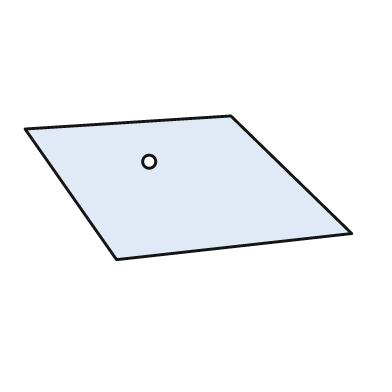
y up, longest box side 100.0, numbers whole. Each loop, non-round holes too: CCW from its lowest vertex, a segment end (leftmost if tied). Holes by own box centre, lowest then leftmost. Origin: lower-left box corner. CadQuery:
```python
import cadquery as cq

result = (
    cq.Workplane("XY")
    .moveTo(28.0, 0.0)
    .lineTo(100.0, 8.0)
    .lineTo(63.0, 44.0)
    .lineTo(0.0, 40.0)
    .close()
    .moveTo(38.0, 30.0)
    .circle(2.0)
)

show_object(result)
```